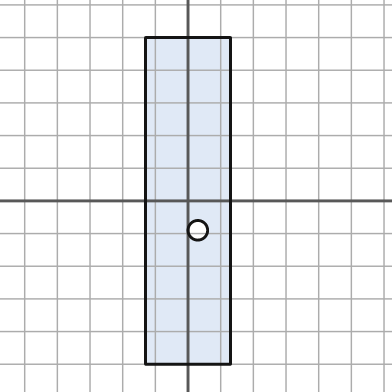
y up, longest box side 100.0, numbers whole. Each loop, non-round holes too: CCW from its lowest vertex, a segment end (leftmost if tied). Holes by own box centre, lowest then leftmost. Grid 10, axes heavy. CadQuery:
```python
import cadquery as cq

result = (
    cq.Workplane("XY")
    .moveTo(-13.0, -50.0)
    .lineTo(13.0, -50.0)
    .lineTo(13.0, 50.0)
    .lineTo(-13.0, 50.0)
    .close()
    .moveTo(3.0, -9.0)
    .circle(3.0)
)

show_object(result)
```